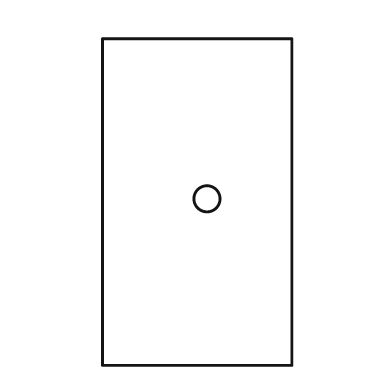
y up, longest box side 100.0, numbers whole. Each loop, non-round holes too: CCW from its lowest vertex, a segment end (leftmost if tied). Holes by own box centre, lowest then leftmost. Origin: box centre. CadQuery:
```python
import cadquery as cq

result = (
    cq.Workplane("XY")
    .moveTo(-29.0, -50.0)
    .lineTo(29.0, -50.0)
    .lineTo(29.0, 50.0)
    .lineTo(-29.0, 50.0)
    .close()
    .moveTo(3.0, 1.0)
    .circle(4.0)
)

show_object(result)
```